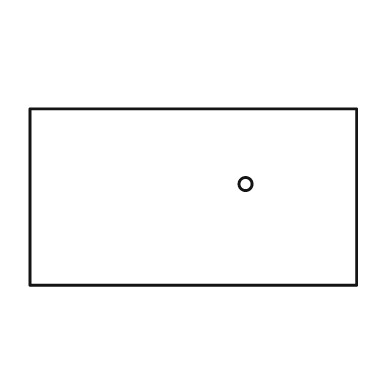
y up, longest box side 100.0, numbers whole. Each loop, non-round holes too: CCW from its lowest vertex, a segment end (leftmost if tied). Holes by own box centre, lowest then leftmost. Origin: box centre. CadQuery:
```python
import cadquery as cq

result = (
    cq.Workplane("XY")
    .moveTo(-50.0, -27.0)
    .lineTo(50.0, -27.0)
    .lineTo(50.0, 27.0)
    .lineTo(-50.0, 27.0)
    .close()
    .moveTo(16.0, 4.0)
    .circle(2.0)
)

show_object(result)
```